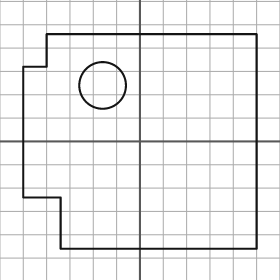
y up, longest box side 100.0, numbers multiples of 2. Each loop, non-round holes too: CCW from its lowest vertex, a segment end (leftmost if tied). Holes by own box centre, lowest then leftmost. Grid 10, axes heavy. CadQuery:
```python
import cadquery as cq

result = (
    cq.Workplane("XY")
    .moveTo(-34.0, -46.0)
    .lineTo(50.0, -46.0)
    .lineTo(50.0, 46.0)
    .lineTo(-40.0, 46.0)
    .lineTo(-40.0, 32.0)
    .lineTo(-50.0, 32.0)
    .lineTo(-50.0, -24.0)
    .lineTo(-34.0, -24.0)
    .close()
    .moveTo(-16.0, 24.0)
    .circle(10.0)
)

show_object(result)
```